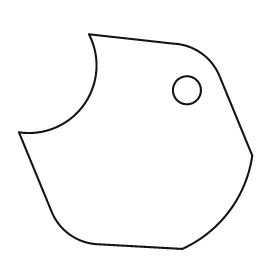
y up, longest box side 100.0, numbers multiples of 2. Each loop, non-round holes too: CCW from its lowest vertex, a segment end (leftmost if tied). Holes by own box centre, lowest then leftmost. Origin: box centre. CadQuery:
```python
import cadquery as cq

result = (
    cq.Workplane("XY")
    .moveTo(20.0, -46.0)
    .threePointArc((40.0, -30.0), (50.0, -6.0))
    .lineTo(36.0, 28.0)
    .threePointArc((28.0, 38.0), (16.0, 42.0))
    .lineTo(-20.0, 46.0)
    .threePointArc((-22.0, 16.0), (-50.0, 4.0))
    .lineTo(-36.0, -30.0)
    .threePointArc((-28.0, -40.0), (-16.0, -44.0))
    .close()
    .moveTo(22.0, 22.0)
    .circle(6.0)
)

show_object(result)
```